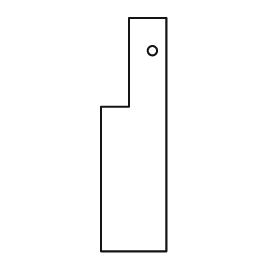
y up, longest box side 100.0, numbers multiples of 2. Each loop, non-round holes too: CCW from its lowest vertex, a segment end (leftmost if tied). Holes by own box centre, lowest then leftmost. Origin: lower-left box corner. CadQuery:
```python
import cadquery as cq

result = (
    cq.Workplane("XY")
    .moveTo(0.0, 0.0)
    .lineTo(28.0, 0.0)
    .lineTo(28.0, 100.0)
    .lineTo(12.0, 100.0)
    .lineTo(12.0, 62.0)
    .lineTo(0.0, 62.0)
    .close()
    .moveTo(22.0, 86.0)
    .circle(2.0)
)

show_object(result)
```